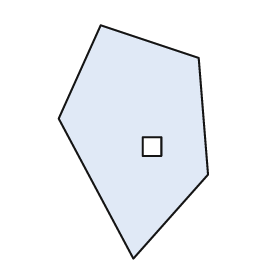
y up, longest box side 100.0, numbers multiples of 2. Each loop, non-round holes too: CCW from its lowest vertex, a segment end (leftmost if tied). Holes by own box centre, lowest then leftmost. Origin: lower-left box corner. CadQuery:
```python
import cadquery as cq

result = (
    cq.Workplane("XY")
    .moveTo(32.0, 0.0)
    .lineTo(64.0, 36.0)
    .lineTo(60.0, 86.0)
    .lineTo(18.0, 100.0)
    .lineTo(0.0, 60.0)
    .close()
    .moveTo(36.0, 44.0)
    .lineTo(44.0, 44.0)
    .lineTo(44.0, 52.0)
    .lineTo(36.0, 52.0)
    .close()
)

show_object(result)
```